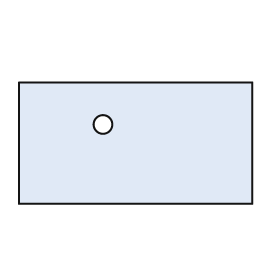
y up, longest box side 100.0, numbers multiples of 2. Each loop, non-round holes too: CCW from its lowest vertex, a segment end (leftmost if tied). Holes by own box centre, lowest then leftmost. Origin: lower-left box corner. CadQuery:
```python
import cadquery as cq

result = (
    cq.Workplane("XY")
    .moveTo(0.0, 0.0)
    .lineTo(100.0, 0.0)
    .lineTo(100.0, 52.0)
    .lineTo(0.0, 52.0)
    .close()
    .moveTo(36.0, 34.0)
    .circle(4.0)
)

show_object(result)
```